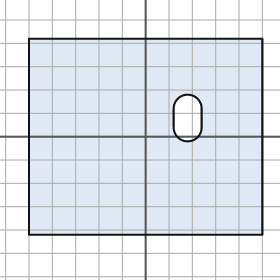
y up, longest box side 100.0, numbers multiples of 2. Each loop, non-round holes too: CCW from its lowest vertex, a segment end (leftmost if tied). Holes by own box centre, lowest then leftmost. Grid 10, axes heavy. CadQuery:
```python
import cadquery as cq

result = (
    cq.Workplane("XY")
    .moveTo(-50.0, -42.0)
    .lineTo(50.0, -42.0)
    .lineTo(50.0, 42.0)
    .lineTo(-50.0, 42.0)
    .close()
    .moveTo(12.0, 4.0)
    .threePointArc((18.0, -2.0), (24.0, 4.0))
    .lineTo(24.0, 12.0)
    .threePointArc((18.0, 18.0), (12.0, 12.0))
    .close()
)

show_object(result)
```